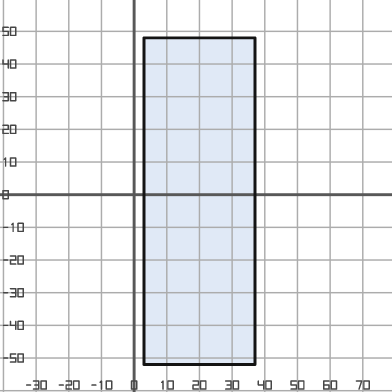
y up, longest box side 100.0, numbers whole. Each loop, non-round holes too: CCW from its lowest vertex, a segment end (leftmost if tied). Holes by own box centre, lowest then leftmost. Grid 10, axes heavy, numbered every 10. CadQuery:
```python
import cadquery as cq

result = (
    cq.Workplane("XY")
    .moveTo(3.0, -52.0)
    .lineTo(37.0, -52.0)
    .lineTo(37.0, 48.0)
    .lineTo(3.0, 48.0)
    .close()
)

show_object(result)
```